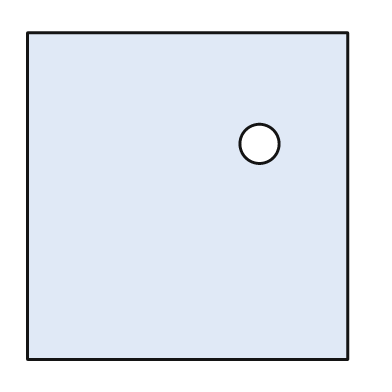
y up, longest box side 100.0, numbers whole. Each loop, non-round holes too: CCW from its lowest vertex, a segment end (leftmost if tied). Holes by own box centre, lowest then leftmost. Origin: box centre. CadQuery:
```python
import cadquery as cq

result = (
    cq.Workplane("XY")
    .moveTo(-49.0, -50.0)
    .lineTo(49.0, -50.0)
    .lineTo(49.0, 50.0)
    .lineTo(-49.0, 50.0)
    .close()
    .moveTo(22.0, 16.0)
    .circle(6.0)
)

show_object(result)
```